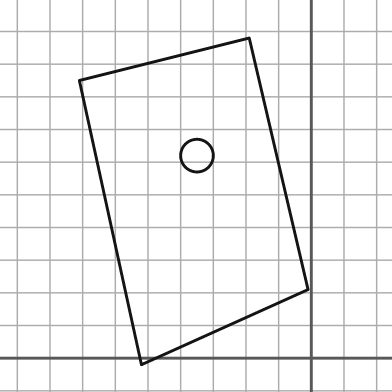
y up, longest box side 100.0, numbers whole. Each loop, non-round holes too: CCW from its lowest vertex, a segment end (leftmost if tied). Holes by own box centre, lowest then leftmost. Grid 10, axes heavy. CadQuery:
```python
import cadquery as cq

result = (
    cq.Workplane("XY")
    .moveTo(-52.0, -2.0)
    .lineTo(-1.0, 21.0)
    .lineTo(-19.0, 98.0)
    .lineTo(-71.0, 85.0)
    .close()
    .moveTo(-35.0, 62.0)
    .circle(5.0)
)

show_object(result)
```